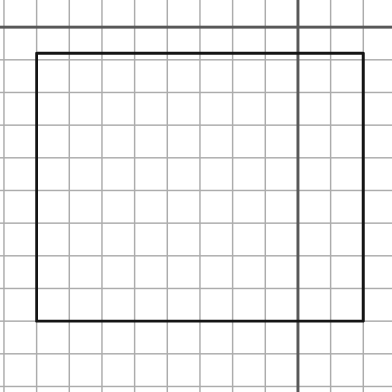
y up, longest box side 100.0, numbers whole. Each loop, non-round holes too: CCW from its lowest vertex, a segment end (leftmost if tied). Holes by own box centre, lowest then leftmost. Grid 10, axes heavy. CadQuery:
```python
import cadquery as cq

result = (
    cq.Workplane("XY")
    .moveTo(-80.0, -90.0)
    .lineTo(20.0, -90.0)
    .lineTo(20.0, -8.0)
    .lineTo(-80.0, -8.0)
    .close()
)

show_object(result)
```